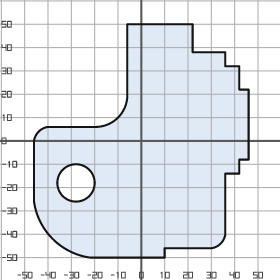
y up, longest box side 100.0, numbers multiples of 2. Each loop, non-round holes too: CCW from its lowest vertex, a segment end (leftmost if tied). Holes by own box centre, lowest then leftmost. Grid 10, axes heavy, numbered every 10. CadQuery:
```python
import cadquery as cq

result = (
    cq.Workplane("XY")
    .moveTo(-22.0, -50.0)
    .lineTo(10.0, -50.0)
    .lineTo(10.0, -46.0)
    .lineTo(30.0, -46.0)
    .threePointArc((34.0, -44.0), (36.0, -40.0))
    .lineTo(36.0, -14.0)
    .lineTo(42.0, -14.0)
    .lineTo(42.0, -8.0)
    .lineTo(46.0, -8.0)
    .lineTo(46.0, 22.0)
    .lineTo(42.0, 22.0)
    .lineTo(42.0, 32.0)
    .lineTo(36.0, 32.0)
    .lineTo(36.0, 38.0)
    .lineTo(22.0, 38.0)
    .lineTo(22.0, 50.0)
    .lineTo(-6.0, 50.0)
    .lineTo(-6.0, 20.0)
    .threePointArc((-10.0, 10.0), (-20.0, 6.0))
    .lineTo(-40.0, 6.0)
    .threePointArc((-44.0, 4.0), (-46.0, 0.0))
    .lineTo(-46.0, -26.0)
    .threePointArc((-38.0, -42.0), (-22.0, -50.0))
    .close()
    .moveTo(-28.0, -18.0)
    .circle(8.0)
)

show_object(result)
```